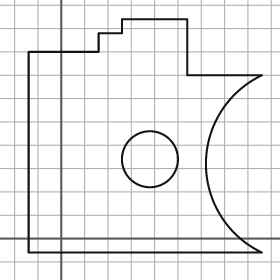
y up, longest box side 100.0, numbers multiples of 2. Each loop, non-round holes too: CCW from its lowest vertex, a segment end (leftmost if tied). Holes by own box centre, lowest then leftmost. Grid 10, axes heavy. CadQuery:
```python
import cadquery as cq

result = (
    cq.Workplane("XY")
    .moveTo(-14.0, -6.0)
    .lineTo(86.0, -6.0)
    .threePointArc((62.0, 32.0), (86.0, 70.0))
    .lineTo(54.0, 70.0)
    .lineTo(54.0, 94.0)
    .lineTo(26.0, 94.0)
    .lineTo(26.0, 88.0)
    .lineTo(16.0, 88.0)
    .lineTo(16.0, 80.0)
    .lineTo(-14.0, 80.0)
    .close()
    .moveTo(38.0, 34.0)
    .circle(12.0)
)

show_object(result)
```